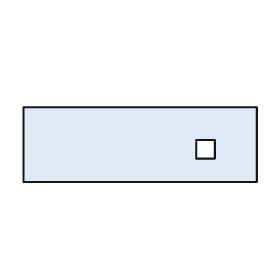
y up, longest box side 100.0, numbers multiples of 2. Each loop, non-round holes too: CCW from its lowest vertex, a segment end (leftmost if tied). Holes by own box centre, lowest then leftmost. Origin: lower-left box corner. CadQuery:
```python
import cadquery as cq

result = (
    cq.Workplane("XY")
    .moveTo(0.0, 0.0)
    .lineTo(100.0, 0.0)
    .lineTo(100.0, 32.0)
    .lineTo(0.0, 32.0)
    .close()
    .moveTo(74.0, 10.0)
    .lineTo(82.0, 10.0)
    .lineTo(82.0, 18.0)
    .lineTo(74.0, 18.0)
    .close()
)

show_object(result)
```